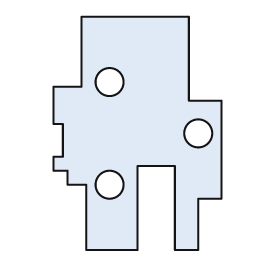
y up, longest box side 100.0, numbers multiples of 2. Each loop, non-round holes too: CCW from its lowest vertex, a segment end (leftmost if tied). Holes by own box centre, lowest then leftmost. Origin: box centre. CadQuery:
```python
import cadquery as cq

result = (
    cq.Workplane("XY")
    .moveTo(-22.0, -50.0)
    .lineTo(0.0, -50.0)
    .lineTo(0.0, -14.0)
    .lineTo(16.0, -14.0)
    .lineTo(16.0, -50.0)
    .lineTo(26.0, -50.0)
    .lineTo(26.0, -28.0)
    .lineTo(36.0, -28.0)
    .lineTo(36.0, 14.0)
    .lineTo(22.0, 14.0)
    .lineTo(22.0, 50.0)
    .lineTo(-24.0, 50.0)
    .lineTo(-24.0, 20.0)
    .lineTo(-36.0, 20.0)
    .lineTo(-36.0, 4.0)
    .lineTo(-32.0, 4.0)
    .lineTo(-32.0, -10.0)
    .lineTo(-36.0, -10.0)
    .lineTo(-36.0, -16.0)
    .lineTo(-30.0, -16.0)
    .lineTo(-30.0, -22.0)
    .lineTo(-22.0, -22.0)
    .close()
    .moveTo(-12.0, -22.0)
    .circle(6.0)
    .moveTo(26.0, 0.0)
    .circle(6.0)
    .moveTo(-12.0, 22.0)
    .circle(6.0)
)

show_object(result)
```